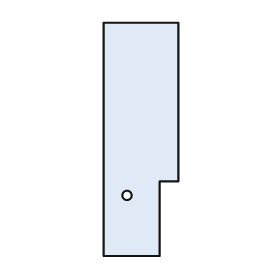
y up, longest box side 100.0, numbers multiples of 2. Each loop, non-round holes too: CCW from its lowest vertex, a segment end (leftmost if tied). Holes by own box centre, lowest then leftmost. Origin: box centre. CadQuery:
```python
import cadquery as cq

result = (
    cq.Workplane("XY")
    .moveTo(-16.0, -50.0)
    .lineTo(8.0, -50.0)
    .lineTo(8.0, -18.0)
    .lineTo(16.0, -18.0)
    .lineTo(16.0, 50.0)
    .lineTo(-16.0, 50.0)
    .close()
    .moveTo(-6.0, -24.0)
    .circle(2.0)
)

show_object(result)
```